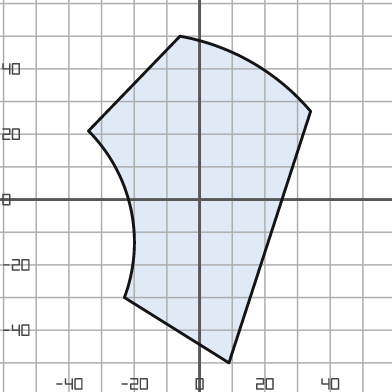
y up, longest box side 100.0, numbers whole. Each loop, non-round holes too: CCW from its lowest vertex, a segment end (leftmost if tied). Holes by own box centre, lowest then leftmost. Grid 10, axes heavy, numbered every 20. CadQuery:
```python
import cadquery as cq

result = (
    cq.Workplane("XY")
    .moveTo(9.0, -50.0)
    .lineTo(34.0, 27.0)
    .threePointArc((16.0, 42.0), (-6.0, 50.0))
    .lineTo(-34.0, 21.0)
    .threePointArc((-21.0, -3.0), (-23.0, -30.0))
    .close()
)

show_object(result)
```